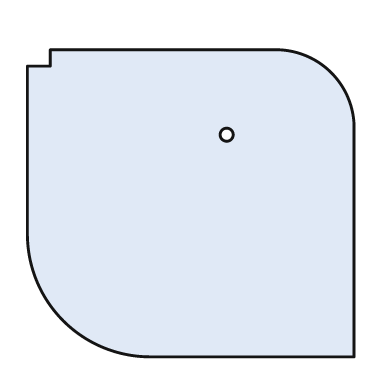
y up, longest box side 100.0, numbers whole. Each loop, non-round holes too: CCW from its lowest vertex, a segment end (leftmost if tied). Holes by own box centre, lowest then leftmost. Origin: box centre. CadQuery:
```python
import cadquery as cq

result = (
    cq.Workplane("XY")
    .moveTo(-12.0, -47.0)
    .lineTo(50.0, -47.0)
    .lineTo(50.0, 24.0)
    .threePointArc((43.0, 40.0), (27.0, 47.0))
    .lineTo(-43.0, 47.0)
    .lineTo(-43.0, 42.0)
    .lineTo(-50.0, 42.0)
    .lineTo(-50.0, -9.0)
    .threePointArc((-39.0, -36.0), (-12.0, -47.0))
    .close()
    .moveTo(11.0, 21.0)
    .circle(2.0)
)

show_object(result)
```